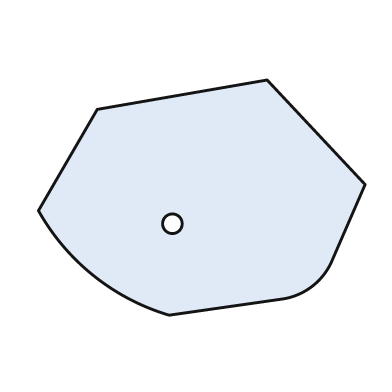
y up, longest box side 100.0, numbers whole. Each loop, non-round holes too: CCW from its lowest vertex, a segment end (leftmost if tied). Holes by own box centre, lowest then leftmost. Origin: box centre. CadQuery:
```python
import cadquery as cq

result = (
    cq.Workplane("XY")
    .moveTo(-10.0, -36.0)
    .lineTo(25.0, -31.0)
    .threePointArc((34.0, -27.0), (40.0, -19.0))
    .lineTo(50.0, 4.0)
    .lineTo(20.0, 36.0)
    .lineTo(-32.0, 27.0)
    .lineTo(-50.0, -4.0)
    .threePointArc((-33.0, -24.0), (-10.0, -36.0))
    .close()
    .moveTo(-9.0, -8.0)
    .circle(3.0)
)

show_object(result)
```